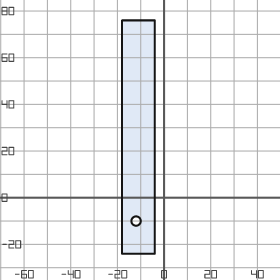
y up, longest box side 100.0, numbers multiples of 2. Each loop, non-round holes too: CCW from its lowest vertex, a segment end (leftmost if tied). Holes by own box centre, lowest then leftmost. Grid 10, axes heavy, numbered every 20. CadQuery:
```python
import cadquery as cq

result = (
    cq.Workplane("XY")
    .moveTo(-18.0, -24.0)
    .lineTo(-4.0, -24.0)
    .lineTo(-4.0, 76.0)
    .lineTo(-18.0, 76.0)
    .close()
    .moveTo(-12.0, -10.0)
    .circle(2.0)
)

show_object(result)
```